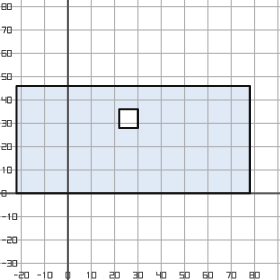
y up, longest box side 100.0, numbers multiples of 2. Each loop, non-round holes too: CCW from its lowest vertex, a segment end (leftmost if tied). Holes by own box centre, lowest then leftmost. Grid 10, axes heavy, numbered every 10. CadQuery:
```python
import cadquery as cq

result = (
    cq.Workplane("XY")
    .moveTo(-22.0, 0.0)
    .lineTo(78.0, 0.0)
    .lineTo(78.0, 46.0)
    .lineTo(-22.0, 46.0)
    .close()
    .moveTo(22.0, 28.0)
    .lineTo(30.0, 28.0)
    .lineTo(30.0, 36.0)
    .lineTo(22.0, 36.0)
    .close()
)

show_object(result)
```